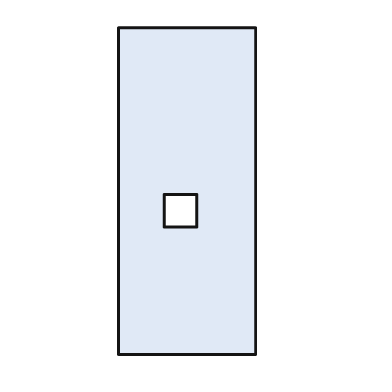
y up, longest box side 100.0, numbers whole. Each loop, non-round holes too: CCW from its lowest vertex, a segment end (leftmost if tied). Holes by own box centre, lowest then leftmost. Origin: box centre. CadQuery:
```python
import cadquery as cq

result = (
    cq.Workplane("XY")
    .moveTo(-21.0, -50.0)
    .lineTo(21.0, -50.0)
    .lineTo(21.0, 50.0)
    .lineTo(-21.0, 50.0)
    .close()
    .moveTo(-7.0, -11.0)
    .lineTo(3.0, -11.0)
    .lineTo(3.0, -1.0)
    .lineTo(-7.0, -1.0)
    .close()
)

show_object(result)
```